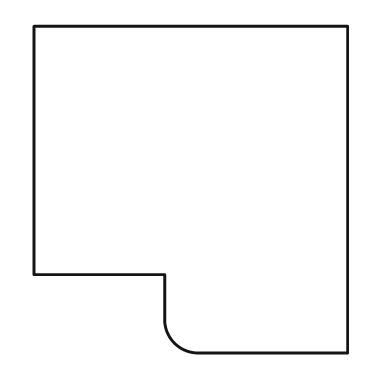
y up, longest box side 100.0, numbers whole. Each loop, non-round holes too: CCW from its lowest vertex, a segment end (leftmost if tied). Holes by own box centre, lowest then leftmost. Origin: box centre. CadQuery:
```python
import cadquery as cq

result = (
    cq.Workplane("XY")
    .moveTo(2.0, -50.0)
    .lineTo(48.0, -50.0)
    .lineTo(48.0, 50.0)
    .lineTo(-48.0, 50.0)
    .lineTo(-48.0, -26.0)
    .lineTo(-8.0, -26.0)
    .lineTo(-8.0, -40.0)
    .threePointArc((-5.0, -47.0), (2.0, -50.0))
    .close()
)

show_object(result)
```